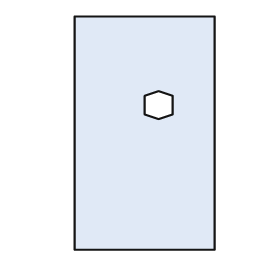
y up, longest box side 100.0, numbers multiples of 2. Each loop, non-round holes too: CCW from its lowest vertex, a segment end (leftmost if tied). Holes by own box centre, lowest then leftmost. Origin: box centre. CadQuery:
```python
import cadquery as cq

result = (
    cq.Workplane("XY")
    .moveTo(-30.0, -50.0)
    .lineTo(30.0, -50.0)
    .lineTo(30.0, 50.0)
    .lineTo(-30.0, 50.0)
    .close()
    .moveTo(6.0, 6.0)
    .lineTo(12.0, 8.0)
    .lineTo(12.0, 16.0)
    .lineTo(6.0, 18.0)
    .lineTo(0.0, 16.0)
    .lineTo(0.0, 8.0)
    .close()
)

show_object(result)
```